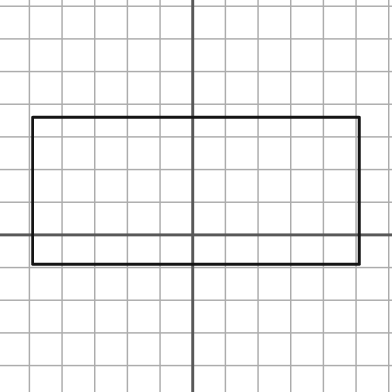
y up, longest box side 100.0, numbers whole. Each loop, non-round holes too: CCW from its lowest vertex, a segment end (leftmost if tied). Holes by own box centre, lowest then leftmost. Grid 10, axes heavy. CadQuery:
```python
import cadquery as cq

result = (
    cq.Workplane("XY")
    .moveTo(-49.0, -9.0)
    .lineTo(51.0, -9.0)
    .lineTo(51.0, 36.0)
    .lineTo(-49.0, 36.0)
    .close()
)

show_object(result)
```